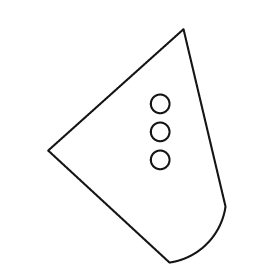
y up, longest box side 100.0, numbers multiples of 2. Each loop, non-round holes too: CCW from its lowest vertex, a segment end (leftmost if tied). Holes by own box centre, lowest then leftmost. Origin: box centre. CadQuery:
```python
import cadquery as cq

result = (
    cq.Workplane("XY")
    .moveTo(14.0, -50.0)
    .threePointArc((30.0, -42.0), (38.0, -26.0))
    .lineTo(20.0, 50.0)
    .lineTo(-38.0, -2.0)
    .close()
    .moveTo(10.0, -6.0)
    .circle(4.0)
    .moveTo(10.0, 6.0)
    .circle(4.0)
    .moveTo(10.0, 18.0)
    .circle(4.0)
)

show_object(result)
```